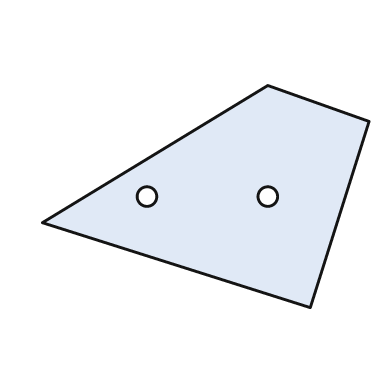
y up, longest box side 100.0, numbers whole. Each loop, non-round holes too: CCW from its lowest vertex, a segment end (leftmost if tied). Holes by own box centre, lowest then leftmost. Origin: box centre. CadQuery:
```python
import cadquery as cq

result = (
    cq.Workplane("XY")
    .moveTo(32.0, -34.0)
    .lineTo(50.0, 23.0)
    .lineTo(19.0, 34.0)
    .lineTo(-50.0, -8.0)
    .close()
    .moveTo(-18.0, 0.0)
    .circle(3.0)
    .moveTo(19.0, 0.0)
    .circle(3.0)
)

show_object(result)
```